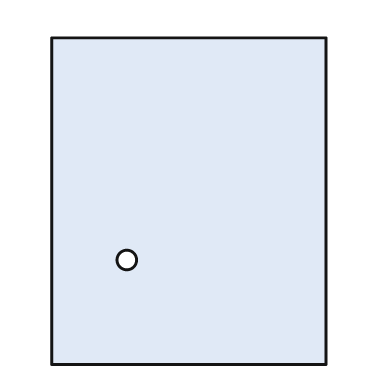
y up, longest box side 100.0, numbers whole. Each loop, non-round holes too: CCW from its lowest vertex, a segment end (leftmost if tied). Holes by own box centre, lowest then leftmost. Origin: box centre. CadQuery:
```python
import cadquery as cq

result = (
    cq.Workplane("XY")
    .moveTo(-42.0, -50.0)
    .lineTo(42.0, -50.0)
    .lineTo(42.0, 50.0)
    .lineTo(-42.0, 50.0)
    .close()
    .moveTo(-19.0, -18.0)
    .circle(3.0)
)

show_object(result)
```